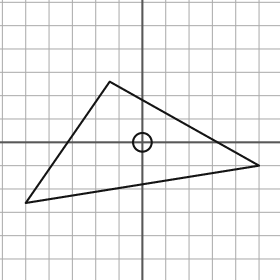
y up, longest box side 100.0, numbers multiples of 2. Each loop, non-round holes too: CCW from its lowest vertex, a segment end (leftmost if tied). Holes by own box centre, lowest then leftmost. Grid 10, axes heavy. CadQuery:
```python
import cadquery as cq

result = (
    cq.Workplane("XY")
    .moveTo(-50.0, -26.0)
    .lineTo(50.0, -10.0)
    .lineTo(-14.0, 26.0)
    .close()
    .moveTo(0.0, 0.0)
    .circle(4.0)
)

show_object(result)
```